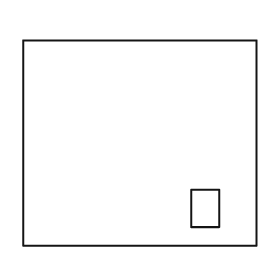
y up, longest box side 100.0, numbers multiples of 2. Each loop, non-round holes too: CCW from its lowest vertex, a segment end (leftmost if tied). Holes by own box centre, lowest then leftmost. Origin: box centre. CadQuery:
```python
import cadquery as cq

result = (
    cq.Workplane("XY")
    .moveTo(-50.0, -44.0)
    .lineTo(50.0, -44.0)
    .lineTo(50.0, 44.0)
    .lineTo(-50.0, 44.0)
    .close()
    .moveTo(22.0, -36.0)
    .lineTo(34.0, -36.0)
    .lineTo(34.0, -20.0)
    .lineTo(22.0, -20.0)
    .close()
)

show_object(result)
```